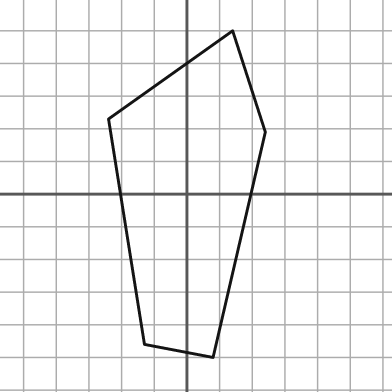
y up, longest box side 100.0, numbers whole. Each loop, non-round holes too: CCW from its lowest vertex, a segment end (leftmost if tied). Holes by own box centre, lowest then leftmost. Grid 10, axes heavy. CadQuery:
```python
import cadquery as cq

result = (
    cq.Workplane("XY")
    .moveTo(8.0, -50.0)
    .lineTo(24.0, 19.0)
    .lineTo(14.0, 50.0)
    .lineTo(-24.0, 23.0)
    .lineTo(-13.0, -46.0)
    .close()
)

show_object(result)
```